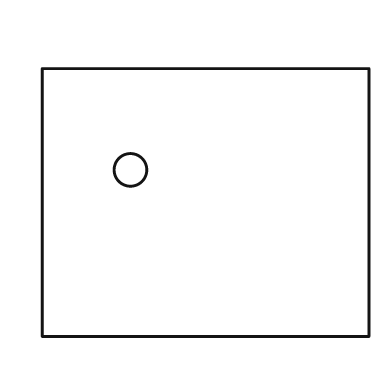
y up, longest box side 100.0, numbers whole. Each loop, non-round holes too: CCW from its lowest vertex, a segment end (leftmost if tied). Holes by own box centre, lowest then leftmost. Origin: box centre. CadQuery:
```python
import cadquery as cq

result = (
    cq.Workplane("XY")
    .moveTo(-50.0, -41.0)
    .lineTo(50.0, -41.0)
    .lineTo(50.0, 41.0)
    .lineTo(-50.0, 41.0)
    .close()
    .moveTo(-23.0, 10.0)
    .circle(5.0)
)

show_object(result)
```